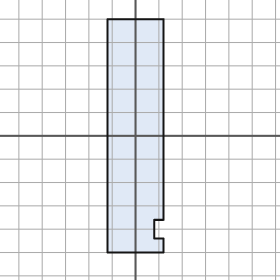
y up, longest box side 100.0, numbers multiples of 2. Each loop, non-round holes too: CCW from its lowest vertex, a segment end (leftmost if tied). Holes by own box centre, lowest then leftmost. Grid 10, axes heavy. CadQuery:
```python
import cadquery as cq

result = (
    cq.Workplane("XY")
    .moveTo(-12.0, -50.0)
    .lineTo(12.0, -50.0)
    .lineTo(12.0, -44.0)
    .lineTo(8.0, -44.0)
    .lineTo(8.0, -36.0)
    .lineTo(12.0, -36.0)
    .lineTo(12.0, 50.0)
    .lineTo(-12.0, 50.0)
    .close()
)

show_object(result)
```